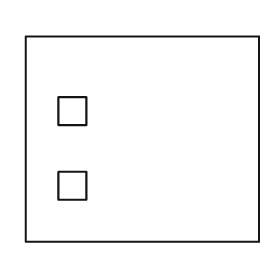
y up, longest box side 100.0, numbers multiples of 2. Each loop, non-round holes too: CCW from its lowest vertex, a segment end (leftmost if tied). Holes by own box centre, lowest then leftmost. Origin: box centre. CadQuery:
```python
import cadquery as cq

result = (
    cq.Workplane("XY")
    .moveTo(-50.0, -44.0)
    .lineTo(50.0, -44.0)
    .lineTo(50.0, 44.0)
    .lineTo(-50.0, 44.0)
    .close()
    .moveTo(-36.0, -26.0)
    .lineTo(-24.0, -26.0)
    .lineTo(-24.0, -14.0)
    .lineTo(-36.0, -14.0)
    .close()
    .moveTo(-36.0, 6.0)
    .lineTo(-24.0, 6.0)
    .lineTo(-24.0, 18.0)
    .lineTo(-36.0, 18.0)
    .close()
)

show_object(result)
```